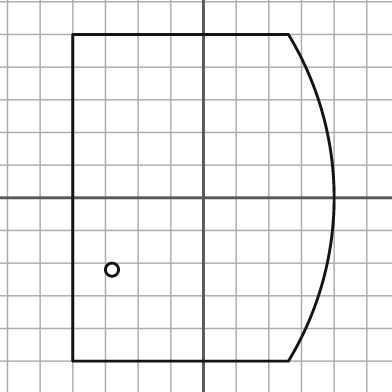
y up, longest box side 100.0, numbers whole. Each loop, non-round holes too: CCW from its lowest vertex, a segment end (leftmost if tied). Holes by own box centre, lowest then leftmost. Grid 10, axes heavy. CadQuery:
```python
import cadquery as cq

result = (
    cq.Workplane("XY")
    .moveTo(-40.0, -50.0)
    .lineTo(26.0, -50.0)
    .threePointArc((40.0, 0.0), (26.0, 50.0))
    .lineTo(-40.0, 50.0)
    .close()
    .moveTo(-28.0, -22.0)
    .circle(2.0)
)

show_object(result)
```